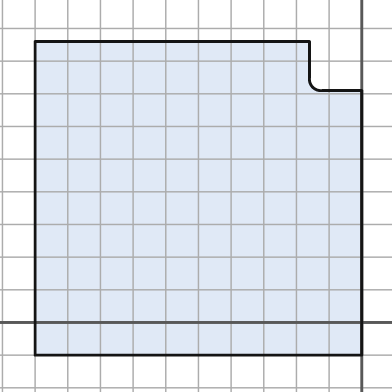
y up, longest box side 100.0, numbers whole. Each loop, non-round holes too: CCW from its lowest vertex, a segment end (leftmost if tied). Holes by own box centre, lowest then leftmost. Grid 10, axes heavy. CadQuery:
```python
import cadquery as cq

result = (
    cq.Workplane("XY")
    .moveTo(-100.0, -10.0)
    .lineTo(0.0, -10.0)
    .lineTo(0.0, 71.0)
    .lineTo(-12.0, 71.0)
    .threePointArc((-15.0, 72.0), (-16.0, 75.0))
    .lineTo(-16.0, 86.0)
    .lineTo(-100.0, 86.0)
    .close()
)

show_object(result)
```